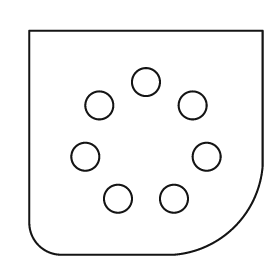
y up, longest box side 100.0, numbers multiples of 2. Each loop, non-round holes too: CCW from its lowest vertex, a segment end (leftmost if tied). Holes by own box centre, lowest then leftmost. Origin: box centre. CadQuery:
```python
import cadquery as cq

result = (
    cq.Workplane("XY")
    .moveTo(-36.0, -48.0)
    .lineTo(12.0, -48.0)
    .threePointArc((38.0, -36.0), (50.0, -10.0))
    .lineTo(50.0, 48.0)
    .lineTo(-50.0, 48.0)
    .lineTo(-50.0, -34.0)
    .threePointArc((-46.0, -44.0), (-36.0, -48.0))
    .close()
    .moveTo(-12.0, -24.0)
    .circle(6.0)
    .moveTo(12.0, -24.0)
    .circle(6.0)
    .moveTo(-26.0, -6.0)
    .circle(6.0)
    .moveTo(26.0, -6.0)
    .circle(6.0)
    .moveTo(-20.0, 16.0)
    .circle(6.0)
    .moveTo(20.0, 16.0)
    .circle(6.0)
    .moveTo(0.0, 26.0)
    .circle(6.0)
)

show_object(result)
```